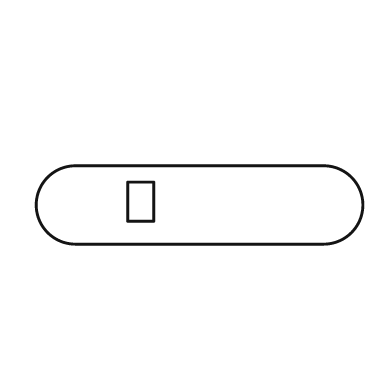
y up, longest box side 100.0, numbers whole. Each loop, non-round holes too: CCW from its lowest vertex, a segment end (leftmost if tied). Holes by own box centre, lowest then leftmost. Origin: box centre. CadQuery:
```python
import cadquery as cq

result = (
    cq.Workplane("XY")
    .moveTo(-38.0, -12.0)
    .lineTo(38.0, -12.0)
    .threePointArc((50.0, 0.0), (38.0, 12.0))
    .lineTo(-38.0, 12.0)
    .threePointArc((-50.0, 0.0), (-38.0, -12.0))
    .close()
    .moveTo(-22.0, -5.0)
    .lineTo(-14.0, -5.0)
    .lineTo(-14.0, 7.0)
    .lineTo(-22.0, 7.0)
    .close()
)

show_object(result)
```